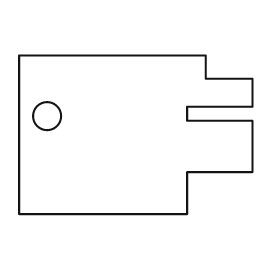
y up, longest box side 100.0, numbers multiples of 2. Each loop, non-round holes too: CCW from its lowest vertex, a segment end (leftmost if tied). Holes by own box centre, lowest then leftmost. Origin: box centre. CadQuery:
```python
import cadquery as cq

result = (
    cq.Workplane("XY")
    .moveTo(-50.0, -34.0)
    .lineTo(22.0, -34.0)
    .lineTo(22.0, -16.0)
    .lineTo(50.0, -16.0)
    .lineTo(50.0, 6.0)
    .lineTo(22.0, 6.0)
    .lineTo(22.0, 12.0)
    .lineTo(50.0, 12.0)
    .lineTo(50.0, 24.0)
    .lineTo(30.0, 24.0)
    .lineTo(30.0, 34.0)
    .lineTo(-50.0, 34.0)
    .close()
    .moveTo(-38.0, 8.0)
    .circle(6.0)
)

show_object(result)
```